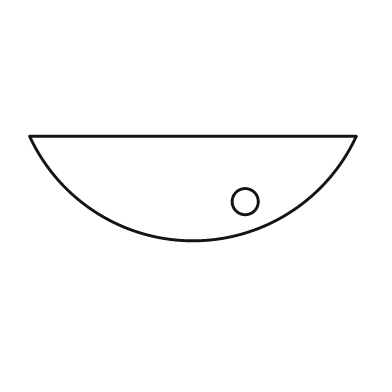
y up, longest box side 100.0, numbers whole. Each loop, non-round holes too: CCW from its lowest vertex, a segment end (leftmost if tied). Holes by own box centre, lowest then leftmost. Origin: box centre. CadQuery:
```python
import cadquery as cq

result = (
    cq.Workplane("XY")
    .moveTo(-50.0, 16.0)
    .threePointArc((0.0, -16.0), (50.0, 16.0))
    .close()
    .moveTo(16.0, -4.0)
    .circle(4.0)
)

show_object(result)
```